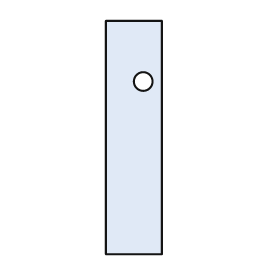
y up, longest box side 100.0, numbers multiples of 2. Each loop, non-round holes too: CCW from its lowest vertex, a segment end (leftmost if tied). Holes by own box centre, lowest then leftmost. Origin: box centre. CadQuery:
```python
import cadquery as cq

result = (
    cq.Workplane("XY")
    .moveTo(-12.0, -50.0)
    .lineTo(12.0, -50.0)
    .lineTo(12.0, 50.0)
    .lineTo(-12.0, 50.0)
    .close()
    .moveTo(4.0, 24.0)
    .circle(4.0)
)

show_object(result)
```